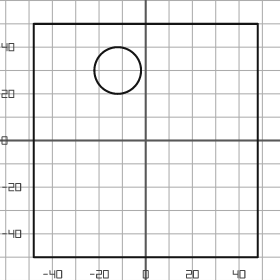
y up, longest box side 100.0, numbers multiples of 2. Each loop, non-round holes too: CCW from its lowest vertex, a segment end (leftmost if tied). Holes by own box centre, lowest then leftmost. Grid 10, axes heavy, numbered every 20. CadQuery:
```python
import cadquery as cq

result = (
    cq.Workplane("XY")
    .moveTo(-48.0, -50.0)
    .lineTo(48.0, -50.0)
    .lineTo(48.0, 50.0)
    .lineTo(-48.0, 50.0)
    .close()
    .moveTo(-12.0, 30.0)
    .circle(10.0)
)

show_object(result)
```